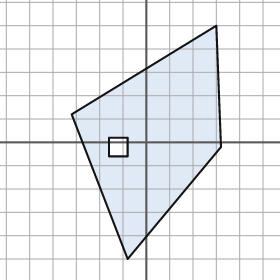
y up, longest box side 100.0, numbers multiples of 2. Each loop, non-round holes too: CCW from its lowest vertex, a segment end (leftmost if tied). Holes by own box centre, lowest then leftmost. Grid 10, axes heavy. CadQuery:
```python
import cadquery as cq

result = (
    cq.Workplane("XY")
    .moveTo(-8.0, -50.0)
    .lineTo(32.0, -2.0)
    .lineTo(30.0, 50.0)
    .lineTo(-32.0, 12.0)
    .close()
    .moveTo(-16.0, -6.0)
    .lineTo(-8.0, -6.0)
    .lineTo(-8.0, 2.0)
    .lineTo(-16.0, 2.0)
    .close()
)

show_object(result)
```